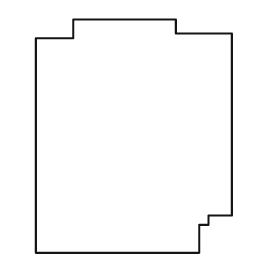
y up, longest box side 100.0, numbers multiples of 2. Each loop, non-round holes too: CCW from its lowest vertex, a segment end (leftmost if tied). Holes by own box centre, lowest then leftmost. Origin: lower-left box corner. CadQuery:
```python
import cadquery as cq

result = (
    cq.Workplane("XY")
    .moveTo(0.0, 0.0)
    .lineTo(70.0, 0.0)
    .lineTo(70.0, 12.0)
    .lineTo(74.0, 12.0)
    .lineTo(74.0, 16.0)
    .lineTo(84.0, 16.0)
    .lineTo(84.0, 94.0)
    .lineTo(60.0, 94.0)
    .lineTo(60.0, 100.0)
    .lineTo(16.0, 100.0)
    .lineTo(16.0, 92.0)
    .lineTo(0.0, 92.0)
    .close()
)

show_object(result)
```